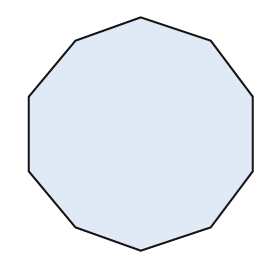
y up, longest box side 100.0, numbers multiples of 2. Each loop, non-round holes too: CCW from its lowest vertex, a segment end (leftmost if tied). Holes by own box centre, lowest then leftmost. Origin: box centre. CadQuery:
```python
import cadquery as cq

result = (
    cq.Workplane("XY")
    .moveTo(0.0, -50.0)
    .lineTo(30.0, -40.0)
    .lineTo(48.0, -16.0)
    .lineTo(48.0, 16.0)
    .lineTo(30.0, 40.0)
    .lineTo(0.0, 50.0)
    .lineTo(-28.0, 40.0)
    .lineTo(-48.0, 16.0)
    .lineTo(-48.0, -16.0)
    .lineTo(-28.0, -40.0)
    .close()
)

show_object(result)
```